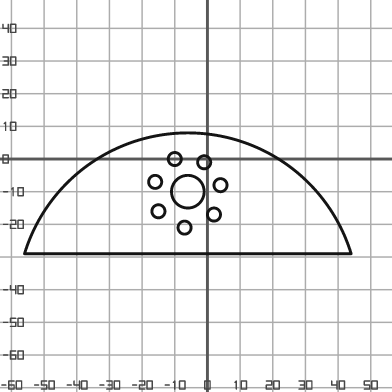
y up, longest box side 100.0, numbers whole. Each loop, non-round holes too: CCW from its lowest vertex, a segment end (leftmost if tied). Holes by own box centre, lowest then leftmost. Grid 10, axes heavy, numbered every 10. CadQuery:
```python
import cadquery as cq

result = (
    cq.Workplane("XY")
    .moveTo(-56.0, -29.0)
    .lineTo(44.0, -29.0)
    .threePointArc((-6.0, 8.0), (-56.0, -29.0))
    .close()
    .moveTo(-7.0, -21.0)
    .circle(2.0)
    .moveTo(2.0, -17.0)
    .circle(2.0)
    .moveTo(-15.0, -16.0)
    .circle(2.0)
    .moveTo(-6.0, -10.0)
    .circle(5.0)
    .moveTo(4.0, -8.0)
    .circle(2.0)
    .moveTo(-16.0, -7.0)
    .circle(2.0)
    .moveTo(-1.0, -1.0)
    .circle(2.0)
    .moveTo(-10.0, 0.0)
    .circle(2.0)
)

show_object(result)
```